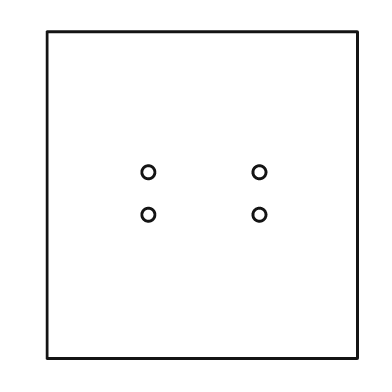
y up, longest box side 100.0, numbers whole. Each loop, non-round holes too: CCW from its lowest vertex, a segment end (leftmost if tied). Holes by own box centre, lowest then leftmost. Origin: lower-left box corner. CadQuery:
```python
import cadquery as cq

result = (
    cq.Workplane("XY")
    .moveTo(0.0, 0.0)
    .lineTo(95.0, 0.0)
    .lineTo(95.0, 100.0)
    .lineTo(0.0, 100.0)
    .close()
    .moveTo(31.0, 44.0)
    .circle(2.0)
    .moveTo(65.0, 44.0)
    .circle(2.0)
    .moveTo(31.0, 57.0)
    .circle(2.0)
    .moveTo(65.0, 57.0)
    .circle(2.0)
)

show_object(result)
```